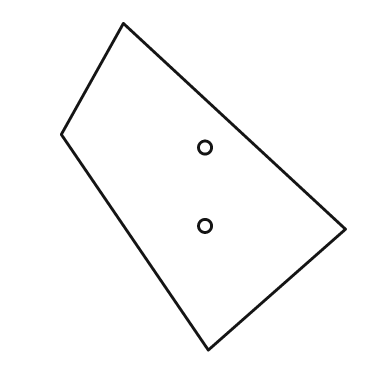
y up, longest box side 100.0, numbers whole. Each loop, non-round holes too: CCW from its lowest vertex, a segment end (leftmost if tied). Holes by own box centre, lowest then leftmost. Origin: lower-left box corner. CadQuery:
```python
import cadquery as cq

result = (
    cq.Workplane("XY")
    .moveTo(45.0, 0.0)
    .lineTo(87.0, 37.0)
    .lineTo(19.0, 100.0)
    .lineTo(0.0, 66.0)
    .close()
    .moveTo(44.0, 38.0)
    .circle(2.0)
    .moveTo(44.0, 62.0)
    .circle(2.0)
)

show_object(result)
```